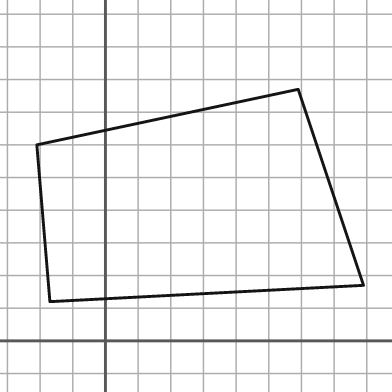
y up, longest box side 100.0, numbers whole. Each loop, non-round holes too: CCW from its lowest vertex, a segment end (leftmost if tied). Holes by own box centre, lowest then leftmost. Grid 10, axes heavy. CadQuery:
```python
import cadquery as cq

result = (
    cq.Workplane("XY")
    .moveTo(-17.0, 12.0)
    .lineTo(79.0, 17.0)
    .lineTo(59.0, 77.0)
    .lineTo(-21.0, 60.0)
    .close()
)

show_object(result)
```